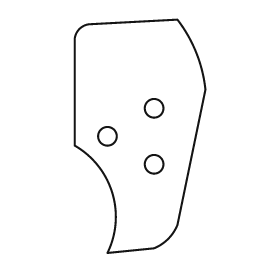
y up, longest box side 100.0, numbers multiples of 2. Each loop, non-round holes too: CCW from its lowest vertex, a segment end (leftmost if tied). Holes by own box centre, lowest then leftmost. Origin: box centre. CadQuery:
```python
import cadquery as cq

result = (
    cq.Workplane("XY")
    .moveTo(-14.0, -50.0)
    .lineTo(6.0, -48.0)
    .threePointArc((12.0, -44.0), (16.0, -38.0))
    .lineTo(28.0, 20.0)
    .threePointArc((24.0, 36.0), (16.0, 50.0))
    .lineTo(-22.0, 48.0)
    .threePointArc((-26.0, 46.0), (-28.0, 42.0))
    .lineTo(-28.0, -4.0)
    .threePointArc((-12.0, -24.0), (-14.0, -50.0))
    .close()
    .moveTo(6.0, -12.0)
    .circle(4.0)
    .moveTo(-14.0, 0.0)
    .circle(4.0)
    .moveTo(6.0, 12.0)
    .circle(4.0)
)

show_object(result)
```